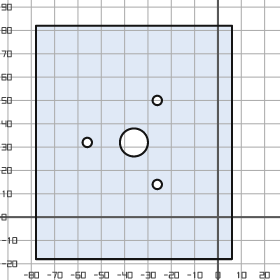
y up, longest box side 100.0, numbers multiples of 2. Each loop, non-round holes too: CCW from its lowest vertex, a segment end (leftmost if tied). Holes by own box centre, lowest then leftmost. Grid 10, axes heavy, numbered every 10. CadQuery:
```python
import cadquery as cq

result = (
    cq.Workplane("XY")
    .moveTo(-78.0, -18.0)
    .lineTo(6.0, -18.0)
    .lineTo(6.0, 82.0)
    .lineTo(-78.0, 82.0)
    .close()
    .moveTo(-26.0, 14.0)
    .circle(2.0)
    .moveTo(-56.0, 32.0)
    .circle(2.0)
    .moveTo(-36.0, 32.0)
    .circle(6.0)
    .moveTo(-26.0, 50.0)
    .circle(2.0)
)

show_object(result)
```